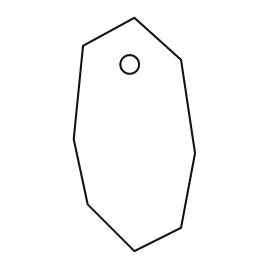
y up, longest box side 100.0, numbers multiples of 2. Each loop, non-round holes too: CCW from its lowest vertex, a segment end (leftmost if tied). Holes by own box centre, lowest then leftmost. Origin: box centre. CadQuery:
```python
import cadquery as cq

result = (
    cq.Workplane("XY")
    .moveTo(0.0, -50.0)
    .lineTo(20.0, -40.0)
    .lineTo(26.0, -8.0)
    .lineTo(20.0, 32.0)
    .lineTo(0.0, 50.0)
    .lineTo(-22.0, 38.0)
    .lineTo(-26.0, -2.0)
    .lineTo(-20.0, -30.0)
    .close()
    .moveTo(-2.0, 30.0)
    .circle(4.0)
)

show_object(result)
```